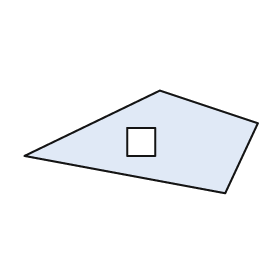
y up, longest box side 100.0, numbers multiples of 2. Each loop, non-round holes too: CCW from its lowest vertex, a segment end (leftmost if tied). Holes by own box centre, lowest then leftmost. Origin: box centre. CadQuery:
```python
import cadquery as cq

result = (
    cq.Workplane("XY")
    .moveTo(36.0, -22.0)
    .lineTo(50.0, 8.0)
    .lineTo(8.0, 22.0)
    .lineTo(-50.0, -6.0)
    .close()
    .moveTo(-6.0, -6.0)
    .lineTo(6.0, -6.0)
    .lineTo(6.0, 6.0)
    .lineTo(-6.0, 6.0)
    .close()
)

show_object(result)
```